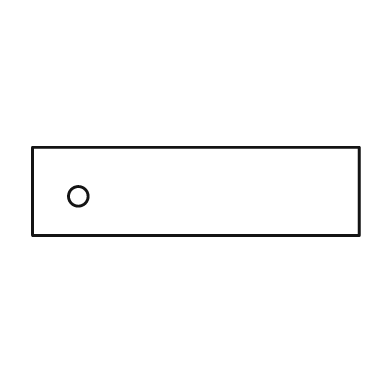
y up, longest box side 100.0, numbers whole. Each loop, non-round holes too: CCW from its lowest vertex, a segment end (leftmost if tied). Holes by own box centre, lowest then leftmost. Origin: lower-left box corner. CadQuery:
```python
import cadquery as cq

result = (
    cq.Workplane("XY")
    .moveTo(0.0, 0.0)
    .lineTo(100.0, 0.0)
    .lineTo(100.0, 27.0)
    .lineTo(0.0, 27.0)
    .close()
    .moveTo(14.0, 12.0)
    .circle(3.0)
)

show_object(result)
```